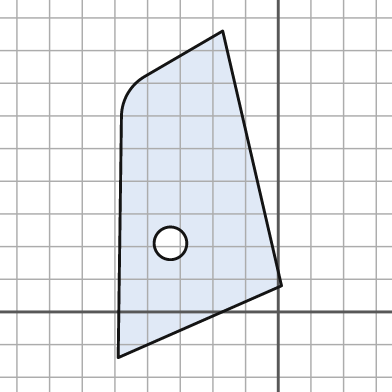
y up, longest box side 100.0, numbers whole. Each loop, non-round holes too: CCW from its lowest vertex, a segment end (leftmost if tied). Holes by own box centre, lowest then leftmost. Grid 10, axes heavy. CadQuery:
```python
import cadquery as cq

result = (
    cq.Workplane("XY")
    .moveTo(-49.0, -14.0)
    .lineTo(1.0, 8.0)
    .lineTo(-17.0, 86.0)
    .lineTo(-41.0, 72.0)
    .threePointArc((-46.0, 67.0), (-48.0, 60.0))
    .close()
    .moveTo(-33.0, 21.0)
    .circle(5.0)
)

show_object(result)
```